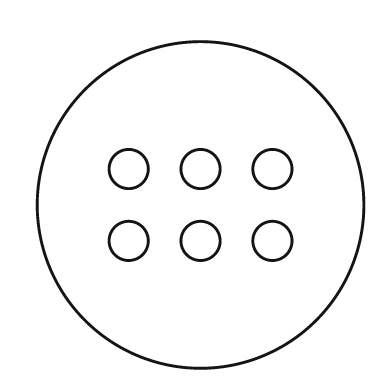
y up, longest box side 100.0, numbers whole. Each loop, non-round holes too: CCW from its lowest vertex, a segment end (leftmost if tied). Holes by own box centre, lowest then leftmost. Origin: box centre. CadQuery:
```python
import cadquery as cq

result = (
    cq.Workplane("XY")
    .moveTo(0.0, 0.0)
    .circle(50.0)
    .moveTo(-22.0, -11.0)
    .circle(6.0)
    .moveTo(0.0, -11.0)
    .circle(6.0)
    .moveTo(22.0, -11.0)
    .circle(6.0)
    .moveTo(-22.0, 11.0)
    .circle(6.0)
    .moveTo(0.0, 11.0)
    .circle(6.0)
    .moveTo(22.0, 11.0)
    .circle(6.0)
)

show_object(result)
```